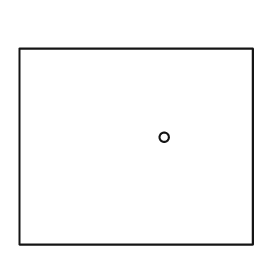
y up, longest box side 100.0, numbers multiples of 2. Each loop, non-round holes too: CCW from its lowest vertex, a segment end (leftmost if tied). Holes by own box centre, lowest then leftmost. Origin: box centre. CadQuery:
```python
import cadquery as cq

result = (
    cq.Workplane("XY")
    .moveTo(-50.0, -42.0)
    .lineTo(50.0, -42.0)
    .lineTo(50.0, 42.0)
    .lineTo(-50.0, 42.0)
    .close()
    .moveTo(12.0, 4.0)
    .circle(2.0)
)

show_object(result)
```